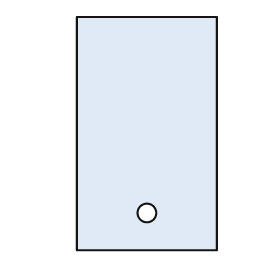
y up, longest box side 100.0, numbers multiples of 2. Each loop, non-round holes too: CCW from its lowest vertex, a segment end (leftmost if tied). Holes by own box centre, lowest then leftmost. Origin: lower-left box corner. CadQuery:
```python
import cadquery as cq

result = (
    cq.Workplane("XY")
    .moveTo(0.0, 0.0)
    .lineTo(60.0, 0.0)
    .lineTo(60.0, 100.0)
    .lineTo(0.0, 100.0)
    .close()
    .moveTo(30.0, 16.0)
    .circle(4.0)
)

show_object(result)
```